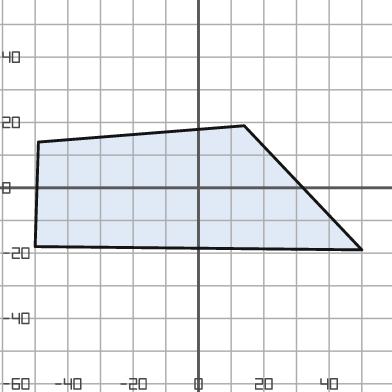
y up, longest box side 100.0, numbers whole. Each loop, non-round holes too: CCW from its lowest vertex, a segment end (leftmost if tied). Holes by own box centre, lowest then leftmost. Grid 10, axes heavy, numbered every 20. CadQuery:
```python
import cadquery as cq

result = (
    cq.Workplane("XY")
    .moveTo(50.0, -19.0)
    .lineTo(14.0, 19.0)
    .lineTo(-49.0, 14.0)
    .lineTo(-50.0, -18.0)
    .close()
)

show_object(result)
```